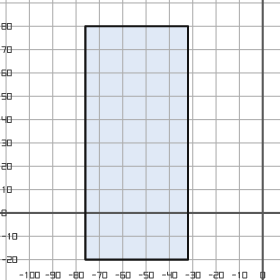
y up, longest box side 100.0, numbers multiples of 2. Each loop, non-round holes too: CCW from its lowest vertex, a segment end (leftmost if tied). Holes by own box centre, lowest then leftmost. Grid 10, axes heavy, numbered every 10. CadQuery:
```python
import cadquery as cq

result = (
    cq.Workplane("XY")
    .moveTo(-76.0, -20.0)
    .lineTo(-32.0, -20.0)
    .lineTo(-32.0, 80.0)
    .lineTo(-76.0, 80.0)
    .close()
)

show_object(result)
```